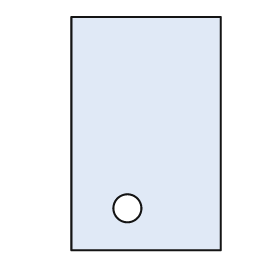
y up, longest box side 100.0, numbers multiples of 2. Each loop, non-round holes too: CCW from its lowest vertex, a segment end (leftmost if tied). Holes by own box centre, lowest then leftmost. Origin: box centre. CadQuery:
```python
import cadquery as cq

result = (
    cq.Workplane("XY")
    .moveTo(-32.0, -50.0)
    .lineTo(32.0, -50.0)
    .lineTo(32.0, 50.0)
    .lineTo(-32.0, 50.0)
    .close()
    .moveTo(-8.0, -32.0)
    .circle(6.0)
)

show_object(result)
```